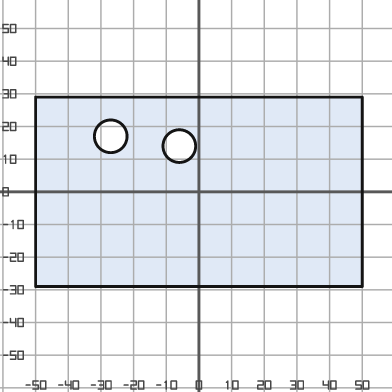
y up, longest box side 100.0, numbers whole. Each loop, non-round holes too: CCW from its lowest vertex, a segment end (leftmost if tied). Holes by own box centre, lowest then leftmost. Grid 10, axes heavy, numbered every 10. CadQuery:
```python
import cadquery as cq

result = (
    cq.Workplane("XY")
    .moveTo(-50.0, -29.0)
    .lineTo(50.0, -29.0)
    .lineTo(50.0, 29.0)
    .lineTo(-50.0, 29.0)
    .close()
    .moveTo(-6.0, 14.0)
    .circle(5.0)
    .moveTo(-27.0, 17.0)
    .circle(5.0)
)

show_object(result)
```